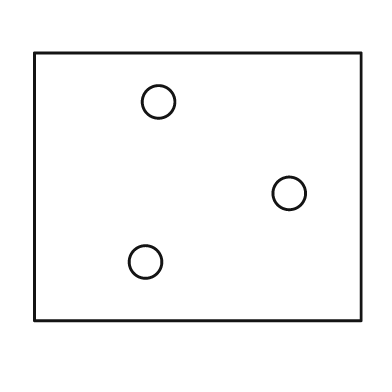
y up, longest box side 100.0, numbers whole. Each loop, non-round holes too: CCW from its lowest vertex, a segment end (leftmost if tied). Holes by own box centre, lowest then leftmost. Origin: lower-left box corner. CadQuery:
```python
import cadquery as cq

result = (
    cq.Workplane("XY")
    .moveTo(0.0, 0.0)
    .lineTo(100.0, 0.0)
    .lineTo(100.0, 82.0)
    .lineTo(0.0, 82.0)
    .close()
    .moveTo(34.0, 18.0)
    .circle(5.0)
    .moveTo(78.0, 39.0)
    .circle(5.0)
    .moveTo(38.0, 67.0)
    .circle(5.0)
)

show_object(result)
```